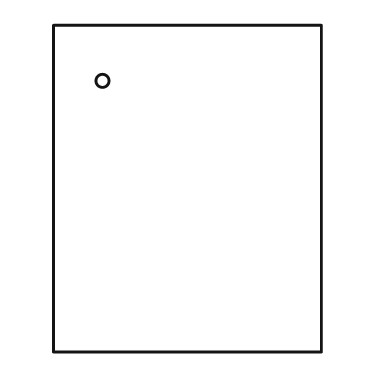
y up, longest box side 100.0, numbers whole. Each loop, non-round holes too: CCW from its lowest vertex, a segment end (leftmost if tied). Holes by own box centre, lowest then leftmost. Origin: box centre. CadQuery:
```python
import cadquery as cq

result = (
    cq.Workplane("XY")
    .moveTo(-41.0, -50.0)
    .lineTo(41.0, -50.0)
    .lineTo(41.0, 50.0)
    .lineTo(-41.0, 50.0)
    .close()
    .moveTo(-26.0, 33.0)
    .circle(2.0)
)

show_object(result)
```